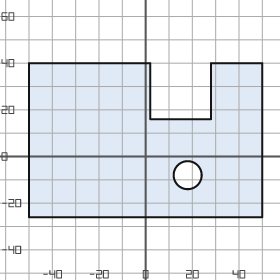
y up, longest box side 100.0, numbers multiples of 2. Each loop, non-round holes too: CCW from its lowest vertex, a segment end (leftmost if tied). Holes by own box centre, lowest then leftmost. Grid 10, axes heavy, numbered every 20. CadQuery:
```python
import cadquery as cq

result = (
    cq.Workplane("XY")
    .moveTo(-50.0, -26.0)
    .lineTo(50.0, -26.0)
    .lineTo(50.0, 40.0)
    .lineTo(28.0, 40.0)
    .lineTo(28.0, 16.0)
    .lineTo(2.0, 16.0)
    .lineTo(2.0, 40.0)
    .lineTo(-50.0, 40.0)
    .close()
    .moveTo(18.0, -8.0)
    .circle(6.0)
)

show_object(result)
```